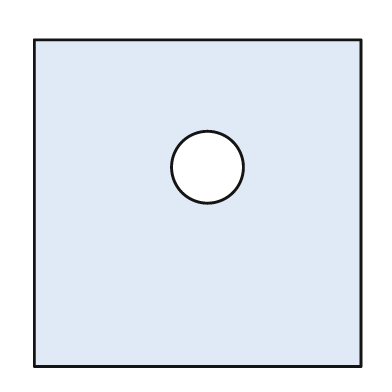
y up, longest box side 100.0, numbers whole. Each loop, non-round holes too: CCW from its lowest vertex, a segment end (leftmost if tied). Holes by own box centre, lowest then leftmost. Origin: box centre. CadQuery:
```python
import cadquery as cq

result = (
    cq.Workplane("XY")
    .moveTo(-50.0, -50.0)
    .lineTo(50.0, -50.0)
    .lineTo(50.0, 50.0)
    .lineTo(-50.0, 50.0)
    .close()
    .moveTo(3.0, 11.0)
    .circle(11.0)
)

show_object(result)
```